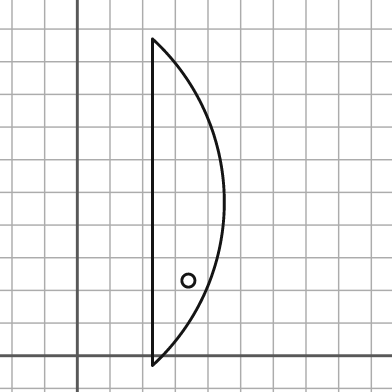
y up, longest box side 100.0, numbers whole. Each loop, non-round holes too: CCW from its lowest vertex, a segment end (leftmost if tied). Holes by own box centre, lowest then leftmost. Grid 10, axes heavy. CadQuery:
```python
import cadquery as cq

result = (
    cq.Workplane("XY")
    .moveTo(23.0, -3.0)
    .threePointArc((45.0, 47.0), (23.0, 97.0))
    .close()
    .moveTo(34.0, 23.0)
    .circle(2.0)
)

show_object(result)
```